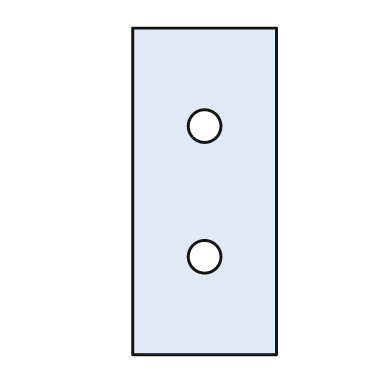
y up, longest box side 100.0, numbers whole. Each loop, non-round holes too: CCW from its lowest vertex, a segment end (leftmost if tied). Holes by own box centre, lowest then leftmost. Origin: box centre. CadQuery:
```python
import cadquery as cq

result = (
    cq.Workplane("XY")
    .moveTo(-22.0, -50.0)
    .lineTo(22.0, -50.0)
    .lineTo(22.0, 50.0)
    .lineTo(-22.0, 50.0)
    .close()
    .moveTo(0.0, -20.0)
    .circle(5.0)
    .moveTo(0.0, 20.0)
    .circle(5.0)
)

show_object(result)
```